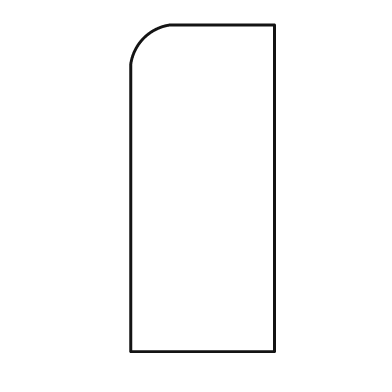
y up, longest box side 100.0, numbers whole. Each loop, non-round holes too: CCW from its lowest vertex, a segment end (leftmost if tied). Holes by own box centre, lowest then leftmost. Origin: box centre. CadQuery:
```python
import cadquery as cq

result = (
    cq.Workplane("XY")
    .moveTo(-22.0, -50.0)
    .lineTo(22.0, -50.0)
    .lineTo(22.0, 50.0)
    .lineTo(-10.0, 50.0)
    .threePointArc((-18.0, 46.0), (-22.0, 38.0))
    .close()
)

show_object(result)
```